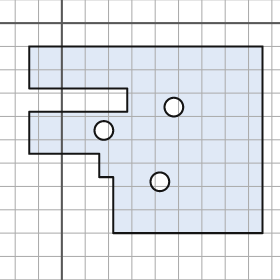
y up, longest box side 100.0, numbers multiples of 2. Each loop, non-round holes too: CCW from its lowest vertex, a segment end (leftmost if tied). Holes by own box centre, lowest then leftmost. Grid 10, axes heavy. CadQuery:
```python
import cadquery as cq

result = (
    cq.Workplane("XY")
    .moveTo(22.0, -90.0)
    .lineTo(86.0, -90.0)
    .lineTo(86.0, -10.0)
    .lineTo(-14.0, -10.0)
    .lineTo(-14.0, -28.0)
    .lineTo(28.0, -28.0)
    .lineTo(28.0, -38.0)
    .lineTo(-14.0, -38.0)
    .lineTo(-14.0, -56.0)
    .lineTo(16.0, -56.0)
    .lineTo(16.0, -66.0)
    .lineTo(22.0, -66.0)
    .close()
    .moveTo(42.0, -68.0)
    .circle(4.0)
    .moveTo(18.0, -46.0)
    .circle(4.0)
    .moveTo(48.0, -36.0)
    .circle(4.0)
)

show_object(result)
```